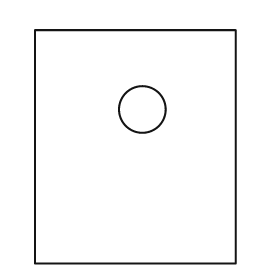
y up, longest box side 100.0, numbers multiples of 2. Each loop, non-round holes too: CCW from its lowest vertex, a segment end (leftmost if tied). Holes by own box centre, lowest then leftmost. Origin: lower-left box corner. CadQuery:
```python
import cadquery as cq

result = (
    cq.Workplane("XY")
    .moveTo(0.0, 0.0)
    .lineTo(86.0, 0.0)
    .lineTo(86.0, 100.0)
    .lineTo(0.0, 100.0)
    .close()
    .moveTo(46.0, 66.0)
    .circle(10.0)
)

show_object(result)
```